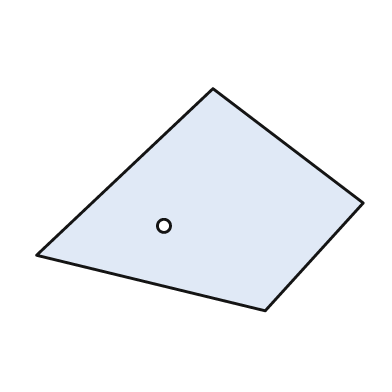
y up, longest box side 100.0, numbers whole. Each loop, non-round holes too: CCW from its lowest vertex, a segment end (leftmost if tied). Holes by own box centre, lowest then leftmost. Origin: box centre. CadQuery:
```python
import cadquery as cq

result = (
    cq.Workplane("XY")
    .moveTo(20.0, -34.0)
    .lineTo(50.0, -1.0)
    .lineTo(4.0, 34.0)
    .lineTo(-50.0, -17.0)
    .close()
    .moveTo(-11.0, -8.0)
    .circle(2.0)
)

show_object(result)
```